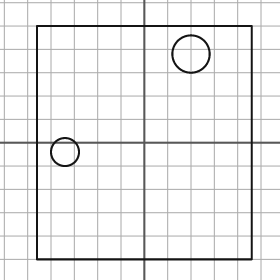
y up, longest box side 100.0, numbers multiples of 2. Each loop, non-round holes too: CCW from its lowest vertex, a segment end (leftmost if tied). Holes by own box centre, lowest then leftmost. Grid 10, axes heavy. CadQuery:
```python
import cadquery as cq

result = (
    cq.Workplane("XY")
    .moveTo(-46.0, -50.0)
    .lineTo(46.0, -50.0)
    .lineTo(46.0, 50.0)
    .lineTo(-46.0, 50.0)
    .close()
    .moveTo(-34.0, -4.0)
    .circle(6.0)
    .moveTo(20.0, 38.0)
    .circle(8.0)
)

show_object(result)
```